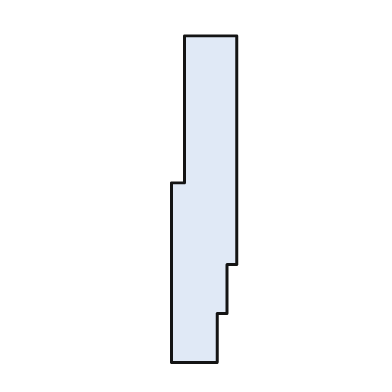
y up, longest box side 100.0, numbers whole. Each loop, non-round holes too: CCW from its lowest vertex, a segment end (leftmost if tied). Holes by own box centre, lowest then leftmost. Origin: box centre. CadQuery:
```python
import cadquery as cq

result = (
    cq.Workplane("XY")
    .moveTo(-10.0, -50.0)
    .lineTo(4.0, -50.0)
    .lineTo(4.0, -35.0)
    .lineTo(7.0, -35.0)
    .lineTo(7.0, -20.0)
    .lineTo(10.0, -20.0)
    .lineTo(10.0, 50.0)
    .lineTo(-6.0, 50.0)
    .lineTo(-6.0, 5.0)
    .lineTo(-10.0, 5.0)
    .close()
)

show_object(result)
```